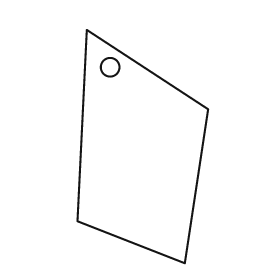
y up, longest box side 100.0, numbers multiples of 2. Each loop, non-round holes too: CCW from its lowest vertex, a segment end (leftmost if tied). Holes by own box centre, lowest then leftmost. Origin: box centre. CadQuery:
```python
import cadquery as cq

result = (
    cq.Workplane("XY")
    .moveTo(18.0, -50.0)
    .lineTo(28.0, 16.0)
    .lineTo(-24.0, 50.0)
    .lineTo(-28.0, -32.0)
    .close()
    .moveTo(-14.0, 34.0)
    .circle(4.0)
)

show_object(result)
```